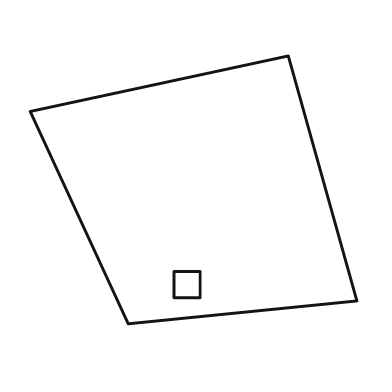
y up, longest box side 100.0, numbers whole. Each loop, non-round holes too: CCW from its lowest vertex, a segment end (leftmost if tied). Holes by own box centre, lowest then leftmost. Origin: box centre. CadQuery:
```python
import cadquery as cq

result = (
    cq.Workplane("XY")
    .moveTo(-20.0, -41.0)
    .lineTo(50.0, -34.0)
    .lineTo(29.0, 41.0)
    .lineTo(-50.0, 24.0)
    .close()
    .moveTo(-6.0, -33.0)
    .lineTo(2.0, -33.0)
    .lineTo(2.0, -25.0)
    .lineTo(-6.0, -25.0)
    .close()
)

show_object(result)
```